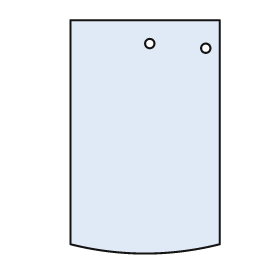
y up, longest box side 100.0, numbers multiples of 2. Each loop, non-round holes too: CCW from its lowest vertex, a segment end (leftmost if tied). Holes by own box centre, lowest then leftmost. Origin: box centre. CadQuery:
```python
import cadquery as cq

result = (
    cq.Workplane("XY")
    .moveTo(-32.0, -46.0)
    .threePointArc((0.0, -50.0), (32.0, -46.0))
    .lineTo(32.0, 50.0)
    .lineTo(-32.0, 50.0)
    .close()
    .moveTo(26.0, 38.0)
    .circle(2.0)
    .moveTo(2.0, 40.0)
    .circle(2.0)
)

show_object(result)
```